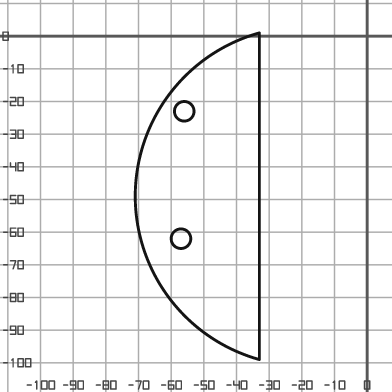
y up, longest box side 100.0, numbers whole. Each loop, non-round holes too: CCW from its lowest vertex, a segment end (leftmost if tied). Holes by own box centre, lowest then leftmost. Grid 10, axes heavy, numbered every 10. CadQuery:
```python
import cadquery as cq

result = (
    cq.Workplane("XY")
    .moveTo(-33.0, -99.0)
    .lineTo(-33.0, 1.0)
    .threePointArc((-71.0, -49.0), (-33.0, -99.0))
    .close()
    .moveTo(-57.0, -62.0)
    .circle(3.0)
    .moveTo(-56.0, -23.0)
    .circle(3.0)
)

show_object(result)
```